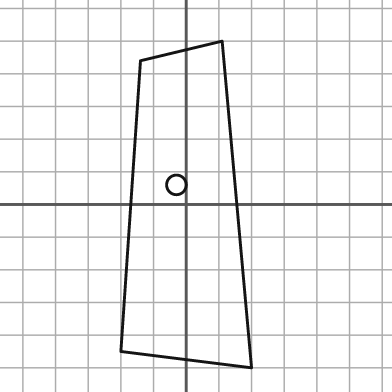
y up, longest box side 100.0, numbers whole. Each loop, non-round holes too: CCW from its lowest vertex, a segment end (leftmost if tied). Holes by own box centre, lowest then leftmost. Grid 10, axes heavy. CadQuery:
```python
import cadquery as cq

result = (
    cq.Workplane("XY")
    .moveTo(20.0, -50.0)
    .lineTo(11.0, 50.0)
    .lineTo(-14.0, 44.0)
    .lineTo(-20.0, -45.0)
    .close()
    .moveTo(-3.0, 6.0)
    .circle(3.0)
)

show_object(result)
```